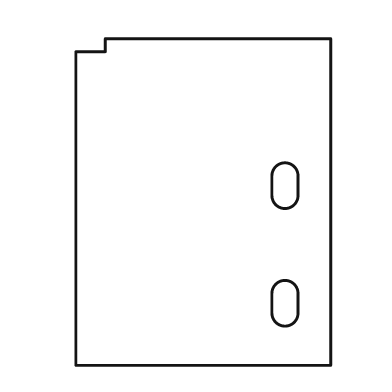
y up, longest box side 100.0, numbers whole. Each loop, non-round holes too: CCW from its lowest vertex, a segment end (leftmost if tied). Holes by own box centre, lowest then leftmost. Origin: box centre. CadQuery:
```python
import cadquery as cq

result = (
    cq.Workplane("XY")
    .moveTo(-39.0, -50.0)
    .lineTo(39.0, -50.0)
    .lineTo(39.0, 50.0)
    .lineTo(-30.0, 50.0)
    .lineTo(-30.0, 46.0)
    .lineTo(-39.0, 46.0)
    .close()
    .moveTo(21.0, -34.0)
    .threePointArc((25.0, -38.0), (29.0, -34.0))
    .lineTo(29.0, -28.0)
    .threePointArc((25.0, -24.0), (21.0, -28.0))
    .close()
    .moveTo(21.0, 2.0)
    .threePointArc((25.0, -2.0), (29.0, 2.0))
    .lineTo(29.0, 8.0)
    .threePointArc((25.0, 12.0), (21.0, 8.0))
    .close()
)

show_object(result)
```